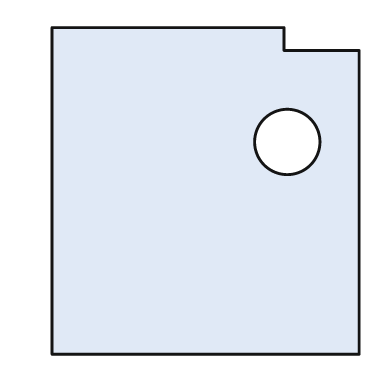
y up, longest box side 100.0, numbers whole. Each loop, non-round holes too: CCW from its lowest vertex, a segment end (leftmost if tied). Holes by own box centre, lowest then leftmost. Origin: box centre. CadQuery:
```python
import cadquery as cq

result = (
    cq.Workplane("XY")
    .moveTo(-47.0, -50.0)
    .lineTo(47.0, -50.0)
    .lineTo(47.0, 43.0)
    .lineTo(24.0, 43.0)
    .lineTo(24.0, 50.0)
    .lineTo(-47.0, 50.0)
    .close()
    .moveTo(25.0, 15.0)
    .circle(10.0)
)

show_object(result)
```